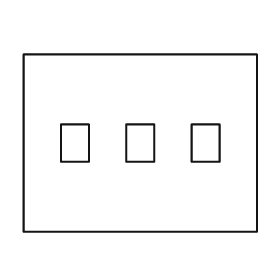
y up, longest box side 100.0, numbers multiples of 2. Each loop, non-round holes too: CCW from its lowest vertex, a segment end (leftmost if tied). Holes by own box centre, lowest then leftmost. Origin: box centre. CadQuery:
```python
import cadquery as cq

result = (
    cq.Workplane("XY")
    .moveTo(-50.0, -38.0)
    .lineTo(50.0, -38.0)
    .lineTo(50.0, 38.0)
    .lineTo(-50.0, 38.0)
    .close()
    .moveTo(-34.0, -8.0)
    .lineTo(-22.0, -8.0)
    .lineTo(-22.0, 8.0)
    .lineTo(-34.0, 8.0)
    .close()
    .moveTo(-6.0, -8.0)
    .lineTo(6.0, -8.0)
    .lineTo(6.0, 8.0)
    .lineTo(-6.0, 8.0)
    .close()
    .moveTo(22.0, -8.0)
    .lineTo(34.0, -8.0)
    .lineTo(34.0, 8.0)
    .lineTo(22.0, 8.0)
    .close()
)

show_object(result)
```